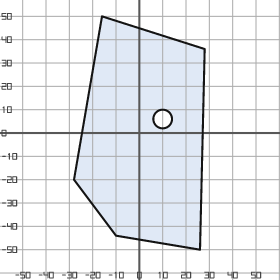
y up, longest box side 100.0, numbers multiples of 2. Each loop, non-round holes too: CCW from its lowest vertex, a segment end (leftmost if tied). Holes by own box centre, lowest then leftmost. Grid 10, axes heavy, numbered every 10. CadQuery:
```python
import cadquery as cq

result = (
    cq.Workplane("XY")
    .moveTo(26.0, -50.0)
    .lineTo(28.0, 36.0)
    .lineTo(-16.0, 50.0)
    .lineTo(-28.0, -20.0)
    .lineTo(-10.0, -44.0)
    .close()
    .moveTo(10.0, 6.0)
    .circle(4.0)
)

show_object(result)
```